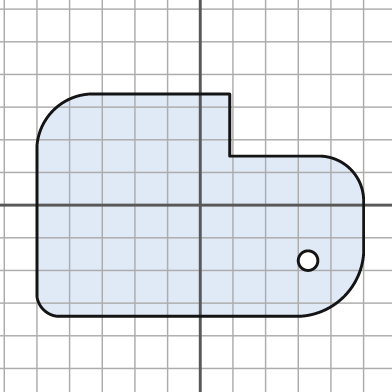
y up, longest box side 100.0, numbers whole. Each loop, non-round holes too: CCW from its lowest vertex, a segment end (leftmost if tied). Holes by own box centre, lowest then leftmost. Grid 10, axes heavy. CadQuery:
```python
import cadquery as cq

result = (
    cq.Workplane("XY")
    .moveTo(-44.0, -34.0)
    .lineTo(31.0, -34.0)
    .threePointArc((44.0, -28.0), (50.0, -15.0))
    .lineTo(50.0, 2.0)
    .threePointArc((46.0, 11.0), (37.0, 15.0))
    .lineTo(9.0, 15.0)
    .lineTo(9.0, 34.0)
    .lineTo(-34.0, 34.0)
    .threePointArc((-45.0, 29.0), (-50.0, 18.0))
    .lineTo(-50.0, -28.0)
    .threePointArc((-48.0, -32.0), (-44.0, -34.0))
    .close()
    .moveTo(33.0, -17.0)
    .circle(3.0)
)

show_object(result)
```